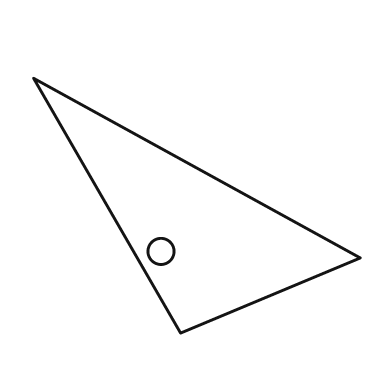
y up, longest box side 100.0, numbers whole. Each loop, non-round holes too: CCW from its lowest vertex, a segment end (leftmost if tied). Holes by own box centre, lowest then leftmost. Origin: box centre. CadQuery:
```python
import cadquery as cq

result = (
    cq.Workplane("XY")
    .moveTo(-5.0, -39.0)
    .lineTo(50.0, -16.0)
    .lineTo(-50.0, 39.0)
    .close()
    .moveTo(-11.0, -14.0)
    .circle(4.0)
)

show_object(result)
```